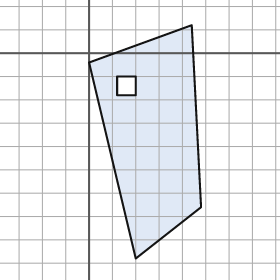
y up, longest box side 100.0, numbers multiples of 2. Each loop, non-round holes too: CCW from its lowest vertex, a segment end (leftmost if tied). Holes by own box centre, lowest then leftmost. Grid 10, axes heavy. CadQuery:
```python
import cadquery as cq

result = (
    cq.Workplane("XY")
    .moveTo(20.0, -88.0)
    .lineTo(48.0, -66.0)
    .lineTo(44.0, 12.0)
    .lineTo(0.0, -4.0)
    .close()
    .moveTo(12.0, -18.0)
    .lineTo(20.0, -18.0)
    .lineTo(20.0, -10.0)
    .lineTo(12.0, -10.0)
    .close()
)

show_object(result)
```